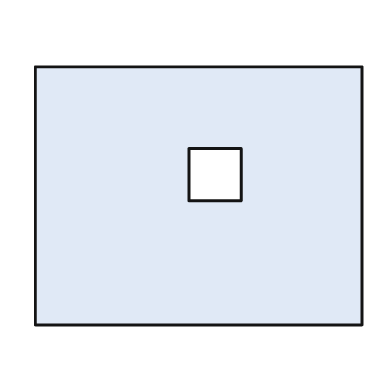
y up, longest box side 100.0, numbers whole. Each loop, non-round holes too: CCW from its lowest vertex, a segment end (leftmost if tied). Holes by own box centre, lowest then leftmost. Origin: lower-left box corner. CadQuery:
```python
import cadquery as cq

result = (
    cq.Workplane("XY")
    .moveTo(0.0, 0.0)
    .lineTo(100.0, 0.0)
    .lineTo(100.0, 79.0)
    .lineTo(0.0, 79.0)
    .close()
    .moveTo(47.0, 38.0)
    .lineTo(63.0, 38.0)
    .lineTo(63.0, 54.0)
    .lineTo(47.0, 54.0)
    .close()
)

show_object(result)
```